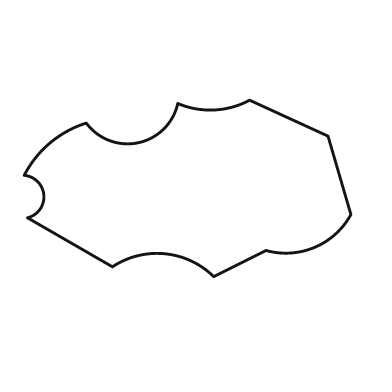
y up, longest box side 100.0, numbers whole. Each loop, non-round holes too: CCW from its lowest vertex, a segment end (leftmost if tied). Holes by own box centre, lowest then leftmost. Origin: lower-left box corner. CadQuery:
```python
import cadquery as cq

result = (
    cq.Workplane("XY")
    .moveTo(58.0, 0.0)
    .lineTo(74.0, 8.0)
    .threePointArc((89.0, 9.0), (100.0, 19.0))
    .lineTo(93.0, 43.0)
    .lineTo(69.0, 54.0)
    .threePointArc((58.0, 51.0), (47.0, 53.0))
    .threePointArc((35.0, 41.0), (19.0, 47.0))
    .threePointArc((8.0, 41.0), (0.0, 31.0))
    .threePointArc((6.0, 25.0), (1.0, 18.0))
    .lineTo(27.0, 3.0)
    .threePointArc((43.0, 7.0), (58.0, 0.0))
    .close()
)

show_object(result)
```